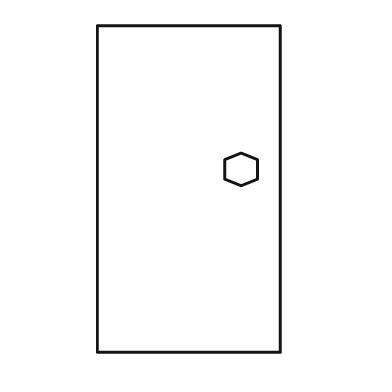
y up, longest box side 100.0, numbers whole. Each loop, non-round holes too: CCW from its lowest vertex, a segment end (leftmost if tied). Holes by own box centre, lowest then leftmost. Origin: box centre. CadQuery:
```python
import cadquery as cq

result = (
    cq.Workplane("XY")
    .moveTo(-28.0, -50.0)
    .lineTo(28.0, -50.0)
    .lineTo(28.0, 50.0)
    .lineTo(-28.0, 50.0)
    .close()
    .moveTo(16.0, 1.0)
    .lineTo(21.0, 3.0)
    .lineTo(21.0, 9.0)
    .lineTo(16.0, 11.0)
    .lineTo(11.0, 9.0)
    .lineTo(11.0, 3.0)
    .close()
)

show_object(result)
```